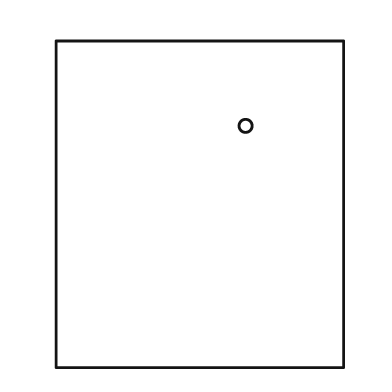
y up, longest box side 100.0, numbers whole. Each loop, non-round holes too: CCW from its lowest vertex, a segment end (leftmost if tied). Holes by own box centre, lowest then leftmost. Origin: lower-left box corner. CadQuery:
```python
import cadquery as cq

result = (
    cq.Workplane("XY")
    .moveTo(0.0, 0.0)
    .lineTo(88.0, 0.0)
    .lineTo(88.0, 100.0)
    .lineTo(0.0, 100.0)
    .close()
    .moveTo(58.0, 74.0)
    .circle(2.0)
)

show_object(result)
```